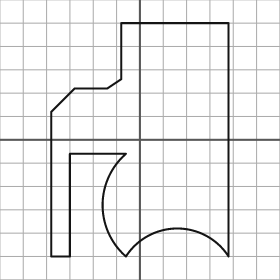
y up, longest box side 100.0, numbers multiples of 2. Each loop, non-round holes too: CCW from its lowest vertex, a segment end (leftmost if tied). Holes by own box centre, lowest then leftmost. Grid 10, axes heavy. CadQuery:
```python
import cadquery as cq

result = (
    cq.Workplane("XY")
    .moveTo(-38.0, -50.0)
    .lineTo(-30.0, -50.0)
    .lineTo(-30.0, -6.0)
    .lineTo(-6.0, -6.0)
    .threePointArc((-16.0, -28.0), (-6.0, -50.0))
    .threePointArc((16.0, -38.0), (38.0, -50.0))
    .lineTo(38.0, 50.0)
    .lineTo(-8.0, 50.0)
    .lineTo(-8.0, 26.0)
    .lineTo(-14.0, 22.0)
    .lineTo(-28.0, 22.0)
    .lineTo(-38.0, 12.0)
    .close()
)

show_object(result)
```